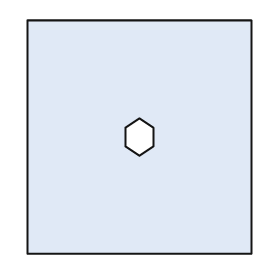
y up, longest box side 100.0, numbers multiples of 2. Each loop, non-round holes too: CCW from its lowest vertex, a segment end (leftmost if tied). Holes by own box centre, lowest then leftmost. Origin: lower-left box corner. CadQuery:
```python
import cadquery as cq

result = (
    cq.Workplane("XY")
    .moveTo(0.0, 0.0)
    .lineTo(96.0, 0.0)
    .lineTo(96.0, 100.0)
    .lineTo(0.0, 100.0)
    .close()
    .moveTo(48.0, 42.0)
    .lineTo(54.0, 46.0)
    .lineTo(54.0, 54.0)
    .lineTo(48.0, 58.0)
    .lineTo(42.0, 54.0)
    .lineTo(42.0, 46.0)
    .close()
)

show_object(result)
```